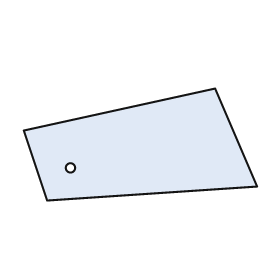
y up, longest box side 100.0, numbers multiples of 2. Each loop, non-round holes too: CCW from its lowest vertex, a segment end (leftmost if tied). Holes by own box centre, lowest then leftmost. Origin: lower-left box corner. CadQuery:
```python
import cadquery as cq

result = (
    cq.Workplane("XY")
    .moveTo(10.0, 0.0)
    .lineTo(100.0, 6.0)
    .lineTo(82.0, 48.0)
    .lineTo(0.0, 30.0)
    .close()
    .moveTo(20.0, 14.0)
    .circle(2.0)
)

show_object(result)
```